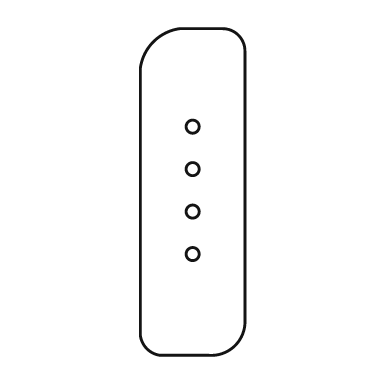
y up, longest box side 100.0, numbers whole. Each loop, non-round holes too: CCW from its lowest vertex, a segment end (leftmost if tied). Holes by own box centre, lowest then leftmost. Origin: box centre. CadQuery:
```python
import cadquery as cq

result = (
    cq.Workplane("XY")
    .moveTo(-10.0, -50.0)
    .lineTo(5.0, -50.0)
    .threePointArc((13.0, -47.0), (16.0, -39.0))
    .lineTo(16.0, 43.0)
    .threePointArc((14.0, 48.0), (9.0, 50.0))
    .lineTo(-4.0, 50.0)
    .threePointArc((-12.0, 46.0), (-16.0, 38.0))
    .lineTo(-16.0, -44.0)
    .threePointArc((-14.0, -48.0), (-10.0, -50.0))
    .close()
    .moveTo(0.0, -19.0)
    .circle(2.0)
    .moveTo(0.0, -6.0)
    .circle(2.0)
    .moveTo(0.0, 7.0)
    .circle(2.0)
    .moveTo(0.0, 20.0)
    .circle(2.0)
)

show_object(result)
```